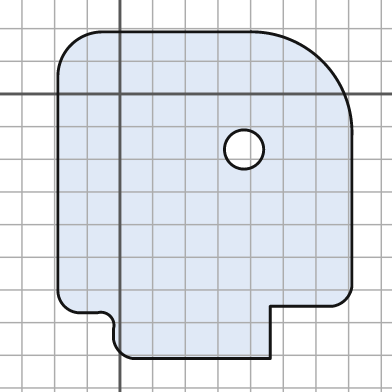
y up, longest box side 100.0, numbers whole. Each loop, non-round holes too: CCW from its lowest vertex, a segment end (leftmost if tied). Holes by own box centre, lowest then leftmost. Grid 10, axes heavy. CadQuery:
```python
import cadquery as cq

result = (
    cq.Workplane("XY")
    .moveTo(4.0, -81.0)
    .lineTo(46.0, -81.0)
    .lineTo(46.0, -65.0)
    .lineTo(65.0, -65.0)
    .threePointArc((69.0, -63.0), (71.0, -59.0))
    .lineTo(71.0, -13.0)
    .threePointArc((62.0, 10.0), (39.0, 19.0))
    .lineTo(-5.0, 19.0)
    .threePointArc((-15.0, 15.0), (-19.0, 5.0))
    .lineTo(-19.0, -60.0)
    .threePointArc((-17.0, -65.0), (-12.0, -67.0))
    .lineTo(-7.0, -67.0)
    .threePointArc((-3.0, -68.0), (-2.0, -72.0))
    .lineTo(-2.0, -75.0)
    .threePointArc((0.0, -79.0), (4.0, -81.0))
    .close()
    .moveTo(38.0, -17.0)
    .circle(6.0)
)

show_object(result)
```